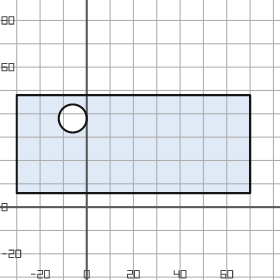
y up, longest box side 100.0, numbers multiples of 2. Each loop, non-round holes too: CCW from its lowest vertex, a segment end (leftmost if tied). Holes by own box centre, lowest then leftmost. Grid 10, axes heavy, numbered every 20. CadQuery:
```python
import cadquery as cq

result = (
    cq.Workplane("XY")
    .moveTo(-30.0, 6.0)
    .lineTo(70.0, 6.0)
    .lineTo(70.0, 48.0)
    .lineTo(-30.0, 48.0)
    .close()
    .moveTo(-6.0, 38.0)
    .circle(6.0)
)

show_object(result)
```